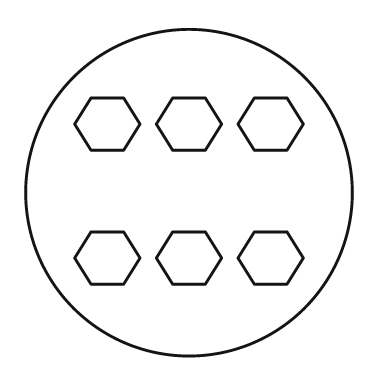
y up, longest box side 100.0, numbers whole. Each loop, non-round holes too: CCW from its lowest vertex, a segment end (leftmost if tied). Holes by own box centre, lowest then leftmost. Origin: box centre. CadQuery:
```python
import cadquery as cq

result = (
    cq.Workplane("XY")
    .moveTo(0.0, 0.0)
    .circle(50.0)
    .moveTo(-30.0, -28.0)
    .lineTo(-20.0, -28.0)
    .lineTo(-15.0, -20.0)
    .lineTo(-20.0, -12.0)
    .lineTo(-30.0, -12.0)
    .lineTo(-35.0, -20.0)
    .close()
    .moveTo(-5.0, -28.0)
    .lineTo(5.0, -28.0)
    .lineTo(10.0, -20.0)
    .lineTo(5.0, -12.0)
    .lineTo(-5.0, -12.0)
    .lineTo(-10.0, -20.0)
    .close()
    .moveTo(20.0, -28.0)
    .lineTo(30.0, -28.0)
    .lineTo(35.0, -20.0)
    .lineTo(30.0, -12.0)
    .lineTo(20.0, -12.0)
    .lineTo(15.0, -20.0)
    .close()
    .moveTo(-30.0, 13.0)
    .lineTo(-20.0, 13.0)
    .lineTo(-15.0, 21.0)
    .lineTo(-20.0, 29.0)
    .lineTo(-30.0, 29.0)
    .lineTo(-35.0, 21.0)
    .close()
    .moveTo(-5.0, 13.0)
    .lineTo(5.0, 13.0)
    .lineTo(10.0, 21.0)
    .lineTo(5.0, 29.0)
    .lineTo(-5.0, 29.0)
    .lineTo(-10.0, 21.0)
    .close()
    .moveTo(20.0, 13.0)
    .lineTo(30.0, 13.0)
    .lineTo(35.0, 21.0)
    .lineTo(30.0, 29.0)
    .lineTo(20.0, 29.0)
    .lineTo(15.0, 21.0)
    .close()
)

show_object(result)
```